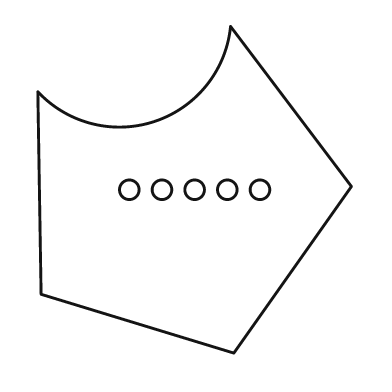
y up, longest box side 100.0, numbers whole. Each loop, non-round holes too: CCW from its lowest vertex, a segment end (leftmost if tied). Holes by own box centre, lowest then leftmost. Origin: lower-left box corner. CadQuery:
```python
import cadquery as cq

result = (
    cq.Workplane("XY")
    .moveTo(60.0, 0.0)
    .lineTo(96.0, 51.0)
    .lineTo(59.0, 100.0)
    .threePointArc((36.0, 71.0), (0.0, 80.0))
    .lineTo(1.0, 18.0)
    .close()
    .moveTo(28.0, 50.0)
    .circle(3.0)
    .moveTo(38.0, 50.0)
    .circle(3.0)
    .moveTo(48.0, 50.0)
    .circle(3.0)
    .moveTo(58.0, 50.0)
    .circle(3.0)
    .moveTo(68.0, 50.0)
    .circle(3.0)
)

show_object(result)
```